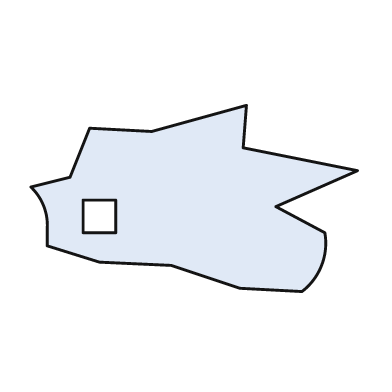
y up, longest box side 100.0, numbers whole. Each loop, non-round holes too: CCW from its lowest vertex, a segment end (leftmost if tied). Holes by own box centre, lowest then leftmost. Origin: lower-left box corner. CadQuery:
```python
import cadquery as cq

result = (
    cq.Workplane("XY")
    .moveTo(83.0, 0.0)
    .threePointArc((89.0, 8.0), (90.0, 18.0))
    .lineTo(75.0, 26.0)
    .lineTo(100.0, 37.0)
    .lineTo(65.0, 44.0)
    .lineTo(66.0, 57.0)
    .lineTo(37.0, 49.0)
    .lineTo(18.0, 50.0)
    .lineTo(12.0, 35.0)
    .lineTo(0.0, 32.0)
    .threePointArc((4.0, 26.0), (5.0, 19.0))
    .lineTo(5.0, 14.0)
    .lineTo(21.0, 9.0)
    .lineTo(43.0, 8.0)
    .lineTo(64.0, 1.0)
    .close()
    .moveTo(16.0, 18.0)
    .lineTo(26.0, 18.0)
    .lineTo(26.0, 28.0)
    .lineTo(16.0, 28.0)
    .close()
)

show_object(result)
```